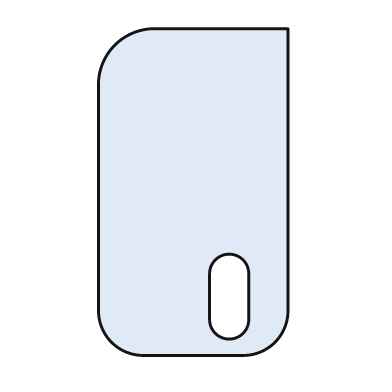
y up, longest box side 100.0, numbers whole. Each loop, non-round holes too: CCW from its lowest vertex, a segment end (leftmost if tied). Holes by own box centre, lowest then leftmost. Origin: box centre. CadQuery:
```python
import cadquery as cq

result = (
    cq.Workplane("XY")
    .moveTo(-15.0, -50.0)
    .lineTo(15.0, -50.0)
    .threePointArc((25.0, -46.0), (29.0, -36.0))
    .lineTo(29.0, 50.0)
    .lineTo(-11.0, 50.0)
    .threePointArc((-24.0, 45.0), (-29.0, 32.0))
    .lineTo(-29.0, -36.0)
    .threePointArc((-25.0, -46.0), (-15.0, -50.0))
    .close()
    .moveTo(5.0, -39.0)
    .threePointArc((11.0, -45.0), (17.0, -39.0))
    .lineTo(17.0, -25.0)
    .threePointArc((11.0, -19.0), (5.0, -25.0))
    .close()
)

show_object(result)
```